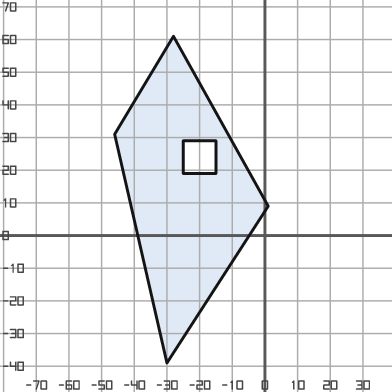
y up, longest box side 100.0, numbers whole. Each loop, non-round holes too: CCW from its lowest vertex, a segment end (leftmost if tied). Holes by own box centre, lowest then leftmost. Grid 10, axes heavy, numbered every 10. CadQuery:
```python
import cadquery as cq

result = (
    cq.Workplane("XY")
    .moveTo(-30.0, -39.0)
    .lineTo(1.0, 9.0)
    .lineTo(-28.0, 61.0)
    .lineTo(-46.0, 31.0)
    .close()
    .moveTo(-25.0, 19.0)
    .lineTo(-15.0, 19.0)
    .lineTo(-15.0, 29.0)
    .lineTo(-25.0, 29.0)
    .close()
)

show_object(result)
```